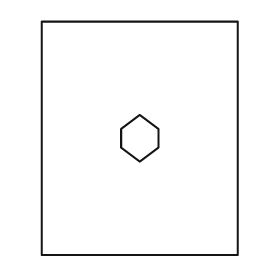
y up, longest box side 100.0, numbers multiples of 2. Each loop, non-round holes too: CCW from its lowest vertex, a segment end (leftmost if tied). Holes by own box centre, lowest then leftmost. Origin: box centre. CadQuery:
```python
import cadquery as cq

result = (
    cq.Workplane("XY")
    .moveTo(-42.0, -50.0)
    .lineTo(42.0, -50.0)
    .lineTo(42.0, 50.0)
    .lineTo(-42.0, 50.0)
    .close()
    .moveTo(0.0, -10.0)
    .lineTo(8.0, -4.0)
    .lineTo(8.0, 4.0)
    .lineTo(0.0, 10.0)
    .lineTo(-8.0, 4.0)
    .lineTo(-8.0, -4.0)
    .close()
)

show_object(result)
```